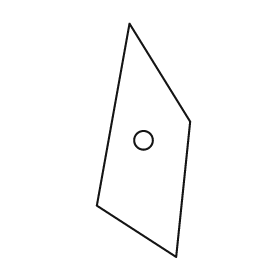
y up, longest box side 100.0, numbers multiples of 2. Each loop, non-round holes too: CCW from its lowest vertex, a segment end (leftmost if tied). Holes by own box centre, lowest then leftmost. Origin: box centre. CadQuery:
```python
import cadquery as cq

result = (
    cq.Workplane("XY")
    .moveTo(14.0, -50.0)
    .lineTo(20.0, 8.0)
    .lineTo(-6.0, 50.0)
    .lineTo(-20.0, -28.0)
    .close()
    .moveTo(0.0, 0.0)
    .circle(4.0)
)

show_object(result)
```